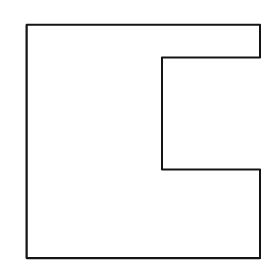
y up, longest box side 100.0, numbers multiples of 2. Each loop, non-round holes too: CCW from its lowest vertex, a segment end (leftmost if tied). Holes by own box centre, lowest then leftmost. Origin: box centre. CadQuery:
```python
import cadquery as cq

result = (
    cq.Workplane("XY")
    .moveTo(-50.0, -50.0)
    .lineTo(50.0, -50.0)
    .lineTo(50.0, -12.0)
    .lineTo(8.0, -12.0)
    .lineTo(8.0, 36.0)
    .lineTo(50.0, 36.0)
    .lineTo(50.0, 50.0)
    .lineTo(-50.0, 50.0)
    .close()
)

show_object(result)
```